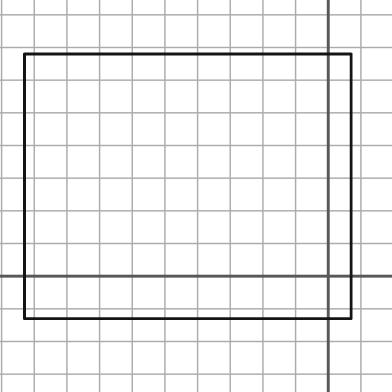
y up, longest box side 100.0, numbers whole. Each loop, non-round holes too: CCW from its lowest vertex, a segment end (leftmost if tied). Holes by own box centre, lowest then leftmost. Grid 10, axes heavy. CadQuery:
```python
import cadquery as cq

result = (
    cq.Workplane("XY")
    .moveTo(-93.0, -13.0)
    .lineTo(7.0, -13.0)
    .lineTo(7.0, 68.0)
    .lineTo(-93.0, 68.0)
    .close()
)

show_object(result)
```